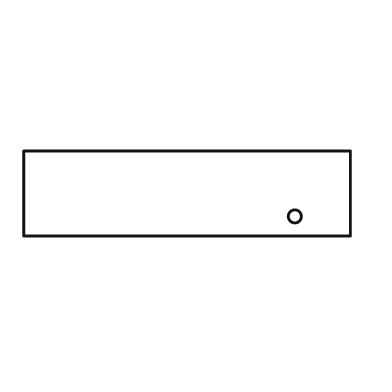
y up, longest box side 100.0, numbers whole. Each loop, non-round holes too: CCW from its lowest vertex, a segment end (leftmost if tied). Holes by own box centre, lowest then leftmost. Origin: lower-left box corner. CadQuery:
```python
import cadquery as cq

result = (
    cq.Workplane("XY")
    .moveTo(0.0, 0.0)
    .lineTo(100.0, 0.0)
    .lineTo(100.0, 26.0)
    .lineTo(0.0, 26.0)
    .close()
    .moveTo(83.0, 6.0)
    .circle(2.0)
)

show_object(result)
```